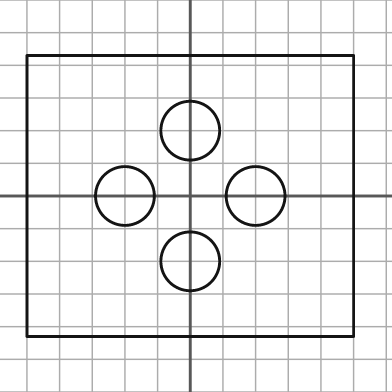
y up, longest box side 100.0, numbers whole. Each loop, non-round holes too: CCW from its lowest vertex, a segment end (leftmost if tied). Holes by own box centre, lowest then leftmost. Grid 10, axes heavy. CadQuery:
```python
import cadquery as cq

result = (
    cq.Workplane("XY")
    .moveTo(-50.0, -43.0)
    .lineTo(50.0, -43.0)
    .lineTo(50.0, 43.0)
    .lineTo(-50.0, 43.0)
    .close()
    .moveTo(0.0, -20.0)
    .circle(9.0)
    .moveTo(-20.0, 0.0)
    .circle(9.0)
    .moveTo(20.0, 0.0)
    .circle(9.0)
    .moveTo(0.0, 20.0)
    .circle(9.0)
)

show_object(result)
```